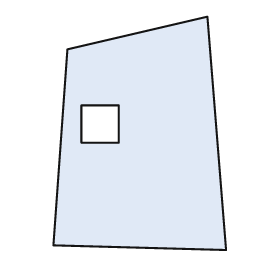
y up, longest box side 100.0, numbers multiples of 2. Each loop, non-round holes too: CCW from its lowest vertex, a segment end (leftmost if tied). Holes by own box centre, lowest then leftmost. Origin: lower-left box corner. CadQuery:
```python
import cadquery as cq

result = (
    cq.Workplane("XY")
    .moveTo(74.0, 0.0)
    .lineTo(66.0, 100.0)
    .lineTo(6.0, 86.0)
    .lineTo(0.0, 2.0)
    .close()
    .moveTo(12.0, 46.0)
    .lineTo(28.0, 46.0)
    .lineTo(28.0, 62.0)
    .lineTo(12.0, 62.0)
    .close()
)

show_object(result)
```